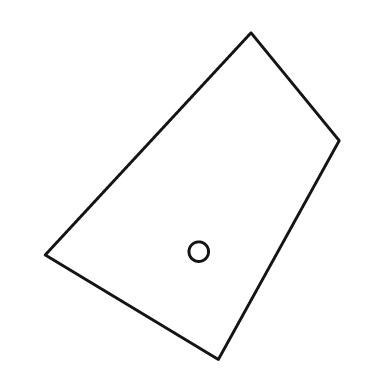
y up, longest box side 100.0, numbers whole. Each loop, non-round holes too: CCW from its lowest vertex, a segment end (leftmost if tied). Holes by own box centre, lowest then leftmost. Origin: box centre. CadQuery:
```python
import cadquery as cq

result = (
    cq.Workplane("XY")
    .moveTo(8.0, -50.0)
    .lineTo(45.0, 17.0)
    .lineTo(18.0, 50.0)
    .lineTo(-45.0, -18.0)
    .close()
    .moveTo(2.0, -17.0)
    .circle(3.0)
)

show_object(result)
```